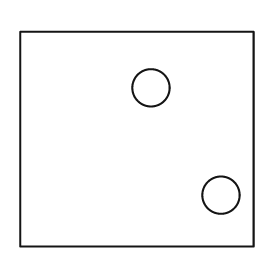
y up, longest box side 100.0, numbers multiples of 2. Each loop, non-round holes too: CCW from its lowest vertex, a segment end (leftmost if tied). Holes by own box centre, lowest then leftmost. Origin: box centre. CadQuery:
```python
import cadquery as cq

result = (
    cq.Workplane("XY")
    .moveTo(-50.0, -46.0)
    .lineTo(50.0, -46.0)
    .lineTo(50.0, 46.0)
    .lineTo(-50.0, 46.0)
    .close()
    .moveTo(36.0, -24.0)
    .circle(8.0)
    .moveTo(6.0, 22.0)
    .circle(8.0)
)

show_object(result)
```